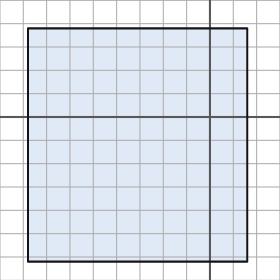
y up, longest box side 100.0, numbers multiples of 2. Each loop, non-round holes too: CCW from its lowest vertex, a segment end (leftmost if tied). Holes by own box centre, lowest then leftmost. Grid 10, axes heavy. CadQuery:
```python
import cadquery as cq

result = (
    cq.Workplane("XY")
    .moveTo(-78.0, -62.0)
    .lineTo(16.0, -62.0)
    .lineTo(16.0, 38.0)
    .lineTo(-78.0, 38.0)
    .close()
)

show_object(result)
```